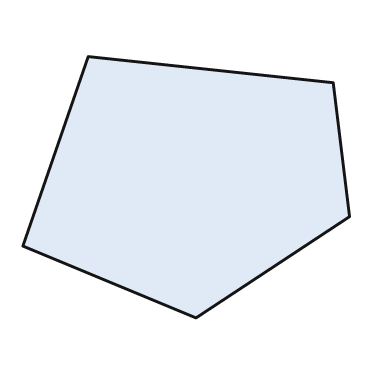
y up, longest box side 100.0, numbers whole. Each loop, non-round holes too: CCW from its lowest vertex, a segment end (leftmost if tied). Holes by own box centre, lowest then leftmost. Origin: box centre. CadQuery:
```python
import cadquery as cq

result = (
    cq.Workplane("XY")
    .moveTo(3.0, -40.0)
    .lineTo(50.0, -9.0)
    .lineTo(45.0, 32.0)
    .lineTo(-30.0, 40.0)
    .lineTo(-50.0, -18.0)
    .close()
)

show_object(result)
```